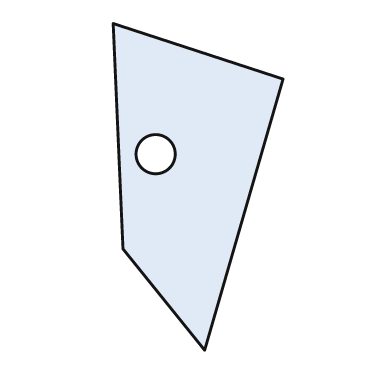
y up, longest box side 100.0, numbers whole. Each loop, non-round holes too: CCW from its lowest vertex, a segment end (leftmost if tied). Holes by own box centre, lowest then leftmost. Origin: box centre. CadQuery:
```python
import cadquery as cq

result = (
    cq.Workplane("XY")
    .moveTo(2.0, -50.0)
    .lineTo(26.0, 33.0)
    .lineTo(-26.0, 50.0)
    .lineTo(-23.0, -19.0)
    .close()
    .moveTo(-13.0, 10.0)
    .circle(6.0)
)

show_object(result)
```